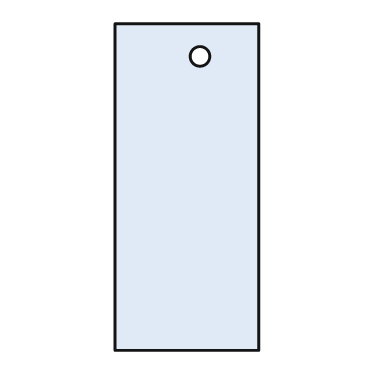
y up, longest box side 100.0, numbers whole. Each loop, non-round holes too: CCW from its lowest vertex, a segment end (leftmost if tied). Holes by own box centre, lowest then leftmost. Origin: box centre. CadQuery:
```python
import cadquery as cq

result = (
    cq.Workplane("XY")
    .moveTo(-22.0, -50.0)
    .lineTo(22.0, -50.0)
    .lineTo(22.0, 50.0)
    .lineTo(-22.0, 50.0)
    .close()
    .moveTo(4.0, 40.0)
    .circle(3.0)
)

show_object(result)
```